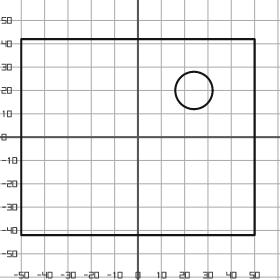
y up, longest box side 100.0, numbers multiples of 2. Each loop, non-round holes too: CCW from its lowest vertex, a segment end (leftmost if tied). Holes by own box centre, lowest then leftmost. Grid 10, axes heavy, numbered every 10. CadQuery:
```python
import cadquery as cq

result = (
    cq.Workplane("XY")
    .moveTo(-50.0, -42.0)
    .lineTo(50.0, -42.0)
    .lineTo(50.0, 42.0)
    .lineTo(-50.0, 42.0)
    .close()
    .moveTo(24.0, 20.0)
    .circle(8.0)
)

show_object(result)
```